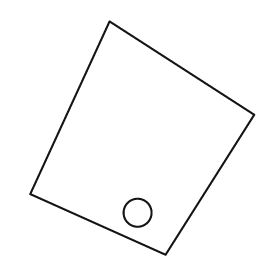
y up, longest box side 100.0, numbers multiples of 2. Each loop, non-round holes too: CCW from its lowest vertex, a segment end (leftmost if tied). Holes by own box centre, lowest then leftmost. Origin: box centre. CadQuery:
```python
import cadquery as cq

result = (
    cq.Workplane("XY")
    .moveTo(10.0, -50.0)
    .lineTo(48.0, 10.0)
    .lineTo(-14.0, 50.0)
    .lineTo(-48.0, -24.0)
    .close()
    .moveTo(-2.0, -32.0)
    .circle(6.0)
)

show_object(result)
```